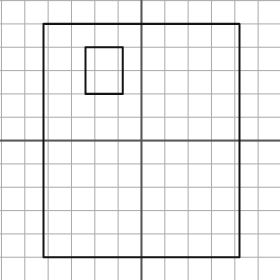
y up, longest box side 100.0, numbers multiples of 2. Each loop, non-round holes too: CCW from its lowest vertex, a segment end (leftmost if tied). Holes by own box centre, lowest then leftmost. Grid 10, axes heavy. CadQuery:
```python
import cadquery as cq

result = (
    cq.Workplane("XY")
    .moveTo(-42.0, -50.0)
    .lineTo(42.0, -50.0)
    .lineTo(42.0, 50.0)
    .lineTo(-42.0, 50.0)
    .close()
    .moveTo(-24.0, 20.0)
    .lineTo(-8.0, 20.0)
    .lineTo(-8.0, 40.0)
    .lineTo(-24.0, 40.0)
    .close()
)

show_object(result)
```